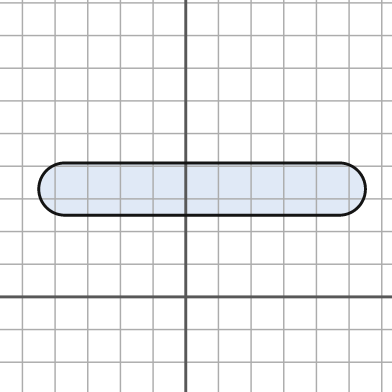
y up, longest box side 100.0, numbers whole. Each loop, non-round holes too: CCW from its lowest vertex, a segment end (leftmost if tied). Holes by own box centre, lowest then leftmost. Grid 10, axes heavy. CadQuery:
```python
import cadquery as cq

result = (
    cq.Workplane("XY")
    .moveTo(-37.0, 25.0)
    .lineTo(47.0, 25.0)
    .threePointArc((55.0, 33.0), (47.0, 41.0))
    .lineTo(-37.0, 41.0)
    .threePointArc((-45.0, 33.0), (-37.0, 25.0))
    .close()
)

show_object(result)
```